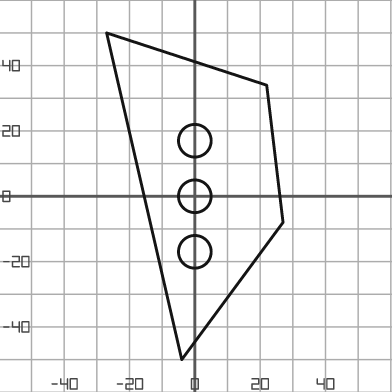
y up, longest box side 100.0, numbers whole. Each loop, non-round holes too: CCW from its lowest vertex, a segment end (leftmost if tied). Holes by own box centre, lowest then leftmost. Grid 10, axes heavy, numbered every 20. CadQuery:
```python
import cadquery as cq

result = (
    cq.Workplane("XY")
    .moveTo(-4.0, -50.0)
    .lineTo(27.0, -8.0)
    .lineTo(22.0, 34.0)
    .lineTo(-27.0, 50.0)
    .close()
    .moveTo(0.0, -17.0)
    .circle(5.0)
    .moveTo(0.0, 0.0)
    .circle(5.0)
    .moveTo(0.0, 17.0)
    .circle(5.0)
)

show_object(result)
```